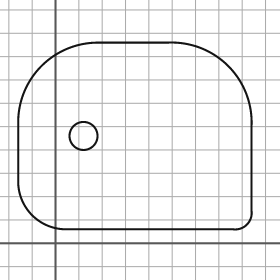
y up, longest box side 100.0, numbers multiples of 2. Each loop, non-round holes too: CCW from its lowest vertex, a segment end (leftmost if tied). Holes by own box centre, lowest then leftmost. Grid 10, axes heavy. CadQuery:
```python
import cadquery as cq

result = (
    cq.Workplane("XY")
    .moveTo(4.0, 6.0)
    .lineTo(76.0, 6.0)
    .threePointArc((82.0, 8.0), (84.0, 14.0))
    .lineTo(84.0, 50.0)
    .threePointArc((74.0, 76.0), (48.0, 86.0))
    .lineTo(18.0, 86.0)
    .threePointArc((-6.0, 76.0), (-16.0, 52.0))
    .lineTo(-16.0, 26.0)
    .threePointArc((-10.0, 12.0), (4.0, 6.0))
    .close()
    .moveTo(12.0, 46.0)
    .circle(6.0)
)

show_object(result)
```